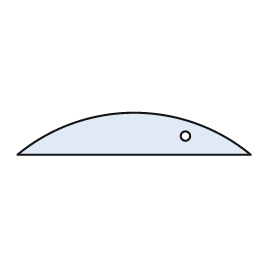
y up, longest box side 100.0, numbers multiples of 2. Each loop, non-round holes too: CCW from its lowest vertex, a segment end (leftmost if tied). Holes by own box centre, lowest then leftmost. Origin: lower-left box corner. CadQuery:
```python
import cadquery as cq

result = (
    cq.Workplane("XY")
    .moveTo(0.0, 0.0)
    .lineTo(100.0, 0.0)
    .threePointArc((50.0, 18.0), (0.0, 0.0))
    .close()
    .moveTo(72.0, 8.0)
    .circle(2.0)
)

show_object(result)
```